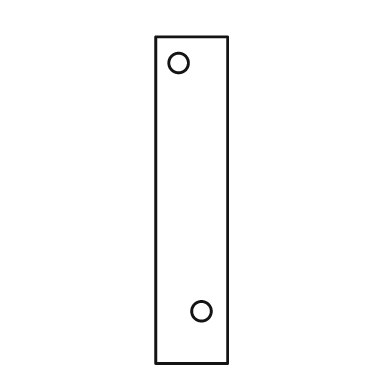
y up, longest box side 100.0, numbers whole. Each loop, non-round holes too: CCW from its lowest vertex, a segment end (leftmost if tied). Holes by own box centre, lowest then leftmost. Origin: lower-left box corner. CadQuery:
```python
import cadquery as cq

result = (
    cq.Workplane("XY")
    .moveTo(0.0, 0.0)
    .lineTo(22.0, 0.0)
    .lineTo(22.0, 100.0)
    .lineTo(0.0, 100.0)
    .close()
    .moveTo(14.0, 16.0)
    .circle(3.0)
    .moveTo(7.0, 92.0)
    .circle(3.0)
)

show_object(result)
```